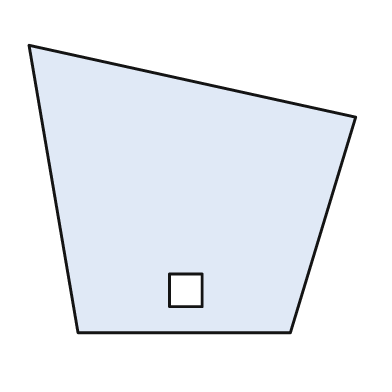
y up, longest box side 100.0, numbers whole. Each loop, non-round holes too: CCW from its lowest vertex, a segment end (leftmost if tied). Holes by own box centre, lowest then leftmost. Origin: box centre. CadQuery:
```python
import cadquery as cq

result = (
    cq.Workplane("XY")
    .moveTo(-35.0, -44.0)
    .lineTo(30.0, -44.0)
    .lineTo(50.0, 22.0)
    .lineTo(-50.0, 44.0)
    .close()
    .moveTo(-7.0, -36.0)
    .lineTo(3.0, -36.0)
    .lineTo(3.0, -26.0)
    .lineTo(-7.0, -26.0)
    .close()
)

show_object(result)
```